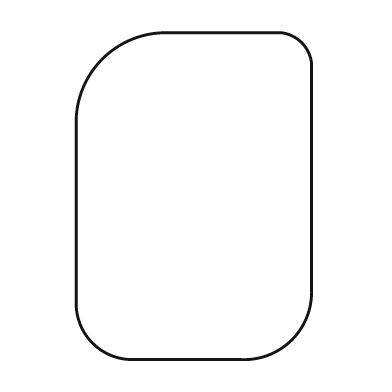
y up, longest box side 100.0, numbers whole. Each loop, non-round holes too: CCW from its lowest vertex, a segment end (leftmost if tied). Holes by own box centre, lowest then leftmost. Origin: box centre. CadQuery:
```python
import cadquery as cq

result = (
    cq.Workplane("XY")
    .moveTo(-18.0, -50.0)
    .lineTo(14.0, -50.0)
    .threePointArc((30.0, -44.0), (36.0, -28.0))
    .lineTo(36.0, 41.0)
    .threePointArc((33.0, 47.0), (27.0, 50.0))
    .lineTo(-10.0, 50.0)
    .threePointArc((-28.0, 42.0), (-36.0, 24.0))
    .lineTo(-36.0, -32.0)
    .threePointArc((-31.0, -45.0), (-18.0, -50.0))
    .close()
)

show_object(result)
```